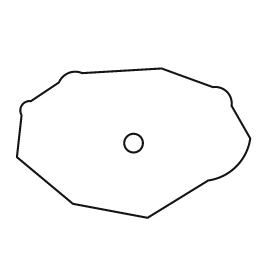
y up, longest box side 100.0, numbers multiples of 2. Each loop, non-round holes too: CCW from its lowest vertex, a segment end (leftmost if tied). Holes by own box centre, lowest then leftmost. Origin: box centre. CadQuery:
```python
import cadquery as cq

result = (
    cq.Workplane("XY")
    .moveTo(6.0, -32.0)
    .lineTo(32.0, -16.0)
    .threePointArc((44.0, -10.0), (50.0, 2.0))
    .lineTo(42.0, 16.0)
    .threePointArc((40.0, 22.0), (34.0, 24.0))
    .lineTo(12.0, 32.0)
    .lineTo(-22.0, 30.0)
    .threePointArc((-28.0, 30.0), (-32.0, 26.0))
    .lineTo(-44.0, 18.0)
    .threePointArc((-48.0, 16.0), (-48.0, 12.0))
    .lineTo(-50.0, -6.0)
    .lineTo(-26.0, -26.0)
    .close()
    .moveTo(0.0, 0.0)
    .circle(4.0)
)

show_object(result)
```